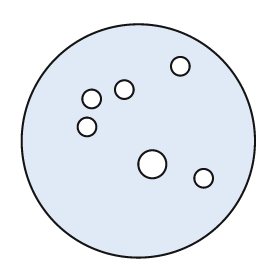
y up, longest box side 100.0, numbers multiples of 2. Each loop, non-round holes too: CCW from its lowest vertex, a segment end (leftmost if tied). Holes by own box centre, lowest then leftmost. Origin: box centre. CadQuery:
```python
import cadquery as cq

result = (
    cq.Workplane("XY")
    .moveTo(0.0, 0.0)
    .circle(50.0)
    .moveTo(28.0, -16.0)
    .circle(4.0)
    .moveTo(6.0, -10.0)
    .circle(6.0)
    .moveTo(-22.0, 6.0)
    .circle(4.0)
    .moveTo(-20.0, 18.0)
    .circle(4.0)
    .moveTo(-6.0, 22.0)
    .circle(4.0)
    .moveTo(18.0, 32.0)
    .circle(4.0)
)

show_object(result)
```